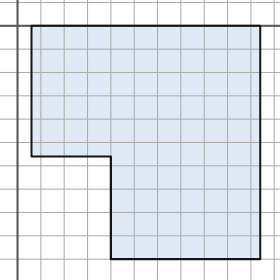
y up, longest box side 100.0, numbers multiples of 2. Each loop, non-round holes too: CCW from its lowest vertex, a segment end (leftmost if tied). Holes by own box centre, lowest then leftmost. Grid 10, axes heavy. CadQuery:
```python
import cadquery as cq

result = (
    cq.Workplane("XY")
    .moveTo(40.0, -100.0)
    .lineTo(104.0, -100.0)
    .lineTo(104.0, 0.0)
    .lineTo(6.0, 0.0)
    .lineTo(6.0, -56.0)
    .lineTo(40.0, -56.0)
    .close()
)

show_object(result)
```